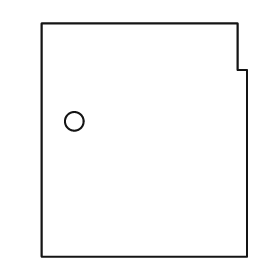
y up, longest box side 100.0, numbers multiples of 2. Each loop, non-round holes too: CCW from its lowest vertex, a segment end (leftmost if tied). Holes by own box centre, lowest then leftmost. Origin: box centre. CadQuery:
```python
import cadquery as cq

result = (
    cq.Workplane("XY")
    .moveTo(-44.0, -50.0)
    .lineTo(44.0, -50.0)
    .lineTo(44.0, 30.0)
    .lineTo(40.0, 30.0)
    .lineTo(40.0, 50.0)
    .lineTo(-44.0, 50.0)
    .close()
    .moveTo(-30.0, 8.0)
    .circle(4.0)
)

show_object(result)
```